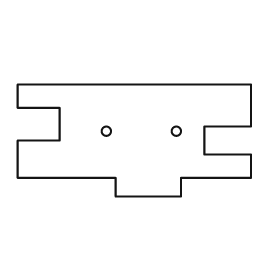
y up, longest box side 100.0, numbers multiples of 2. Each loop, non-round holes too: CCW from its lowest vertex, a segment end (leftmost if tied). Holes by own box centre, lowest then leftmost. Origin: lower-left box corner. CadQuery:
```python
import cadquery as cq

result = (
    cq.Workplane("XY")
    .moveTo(42.0, 0.0)
    .lineTo(70.0, 0.0)
    .lineTo(70.0, 8.0)
    .lineTo(100.0, 8.0)
    .lineTo(100.0, 18.0)
    .lineTo(80.0, 18.0)
    .lineTo(80.0, 30.0)
    .lineTo(100.0, 30.0)
    .lineTo(100.0, 48.0)
    .lineTo(0.0, 48.0)
    .lineTo(0.0, 38.0)
    .lineTo(18.0, 38.0)
    .lineTo(18.0, 24.0)
    .lineTo(0.0, 24.0)
    .lineTo(0.0, 8.0)
    .lineTo(42.0, 8.0)
    .close()
    .moveTo(38.0, 28.0)
    .circle(2.0)
    .moveTo(68.0, 28.0)
    .circle(2.0)
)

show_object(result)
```